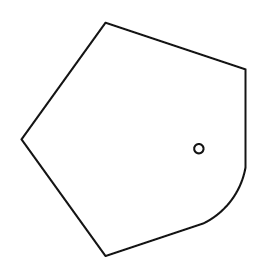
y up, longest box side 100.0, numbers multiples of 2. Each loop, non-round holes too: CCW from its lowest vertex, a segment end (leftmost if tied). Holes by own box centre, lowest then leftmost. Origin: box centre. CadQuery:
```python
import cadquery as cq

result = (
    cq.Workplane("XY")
    .moveTo(-12.0, -50.0)
    .lineTo(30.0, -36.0)
    .threePointArc((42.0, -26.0), (48.0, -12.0))
    .lineTo(48.0, 30.0)
    .lineTo(-12.0, 50.0)
    .lineTo(-48.0, 0.0)
    .close()
    .moveTo(28.0, -4.0)
    .circle(2.0)
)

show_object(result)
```